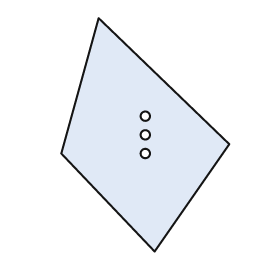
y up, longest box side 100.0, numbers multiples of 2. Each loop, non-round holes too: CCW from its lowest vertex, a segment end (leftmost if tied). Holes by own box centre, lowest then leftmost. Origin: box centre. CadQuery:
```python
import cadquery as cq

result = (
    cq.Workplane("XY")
    .moveTo(4.0, -50.0)
    .lineTo(36.0, -4.0)
    .lineTo(-20.0, 50.0)
    .lineTo(-36.0, -8.0)
    .close()
    .moveTo(0.0, -8.0)
    .circle(2.0)
    .moveTo(0.0, 0.0)
    .circle(2.0)
    .moveTo(0.0, 8.0)
    .circle(2.0)
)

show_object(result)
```